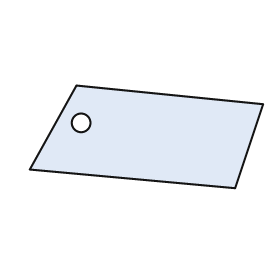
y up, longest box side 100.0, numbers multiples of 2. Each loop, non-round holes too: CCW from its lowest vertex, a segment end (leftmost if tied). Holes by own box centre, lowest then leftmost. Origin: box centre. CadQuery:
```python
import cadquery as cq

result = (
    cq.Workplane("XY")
    .moveTo(38.0, -22.0)
    .lineTo(50.0, 14.0)
    .lineTo(-30.0, 22.0)
    .lineTo(-50.0, -14.0)
    .close()
    .moveTo(-28.0, 6.0)
    .circle(4.0)
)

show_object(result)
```